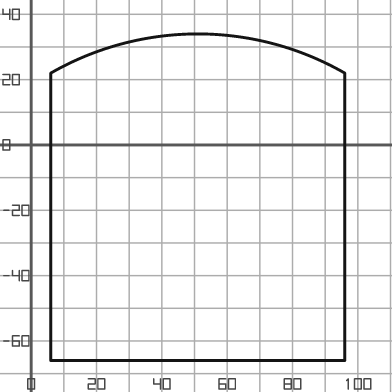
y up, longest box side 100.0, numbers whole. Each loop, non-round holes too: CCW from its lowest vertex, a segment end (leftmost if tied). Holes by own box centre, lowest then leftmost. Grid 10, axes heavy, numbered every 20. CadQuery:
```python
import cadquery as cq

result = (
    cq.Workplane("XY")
    .moveTo(6.0, -66.0)
    .lineTo(96.0, -66.0)
    .lineTo(96.0, 22.0)
    .threePointArc((51.0, 34.0), (6.0, 22.0))
    .close()
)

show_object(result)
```